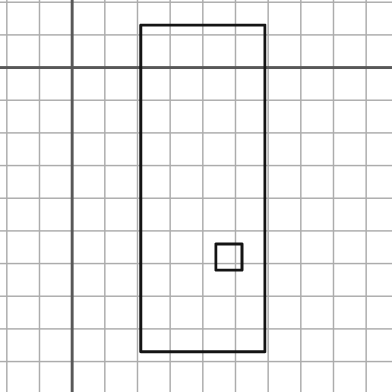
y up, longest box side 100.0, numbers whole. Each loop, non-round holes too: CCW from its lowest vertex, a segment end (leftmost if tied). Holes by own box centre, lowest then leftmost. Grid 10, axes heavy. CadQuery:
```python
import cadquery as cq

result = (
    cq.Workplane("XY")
    .moveTo(21.0, -87.0)
    .lineTo(59.0, -87.0)
    .lineTo(59.0, 13.0)
    .lineTo(21.0, 13.0)
    .close()
    .moveTo(44.0, -62.0)
    .lineTo(52.0, -62.0)
    .lineTo(52.0, -54.0)
    .lineTo(44.0, -54.0)
    .close()
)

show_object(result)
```